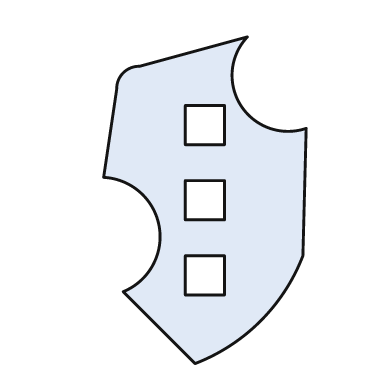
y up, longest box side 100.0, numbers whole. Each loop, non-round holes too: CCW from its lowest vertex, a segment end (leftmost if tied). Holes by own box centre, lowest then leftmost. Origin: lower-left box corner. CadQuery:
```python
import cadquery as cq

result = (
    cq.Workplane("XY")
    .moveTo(28.0, 0.0)
    .threePointArc((48.0, 13.0), (61.0, 33.0))
    .lineTo(62.0, 72.0)
    .threePointArc((42.0, 79.0), (44.0, 100.0))
    .lineTo(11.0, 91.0)
    .threePointArc((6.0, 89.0), (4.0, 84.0))
    .lineTo(0.0, 57.0)
    .threePointArc((17.0, 42.0), (6.0, 22.0))
    .close()
    .moveTo(25.0, 21.0)
    .lineTo(37.0, 21.0)
    .lineTo(37.0, 33.0)
    .lineTo(25.0, 33.0)
    .close()
    .moveTo(25.0, 44.0)
    .lineTo(37.0, 44.0)
    .lineTo(37.0, 56.0)
    .lineTo(25.0, 56.0)
    .close()
    .moveTo(25.0, 67.0)
    .lineTo(37.0, 67.0)
    .lineTo(37.0, 79.0)
    .lineTo(25.0, 79.0)
    .close()
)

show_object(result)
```